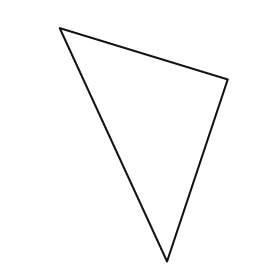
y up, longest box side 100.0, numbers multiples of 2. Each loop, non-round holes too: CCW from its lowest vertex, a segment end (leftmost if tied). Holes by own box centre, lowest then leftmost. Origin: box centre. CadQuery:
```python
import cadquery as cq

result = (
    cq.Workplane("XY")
    .moveTo(10.0, -50.0)
    .lineTo(36.0, 28.0)
    .lineTo(-36.0, 50.0)
    .close()
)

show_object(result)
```